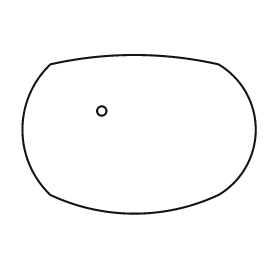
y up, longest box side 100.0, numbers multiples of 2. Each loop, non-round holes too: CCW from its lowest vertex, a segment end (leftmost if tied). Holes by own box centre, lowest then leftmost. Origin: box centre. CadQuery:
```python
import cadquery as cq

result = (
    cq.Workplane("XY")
    .moveTo(-38.0, -26.0)
    .threePointArc((-2.0, -34.0), (34.0, -26.0))
    .threePointArc((50.0, 2.0), (34.0, 30.0))
    .threePointArc((-2.0, 34.0), (-38.0, 30.0))
    .threePointArc((-50.0, 2.0), (-38.0, -26.0))
    .close()
    .moveTo(-16.0, 10.0)
    .circle(2.0)
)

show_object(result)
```